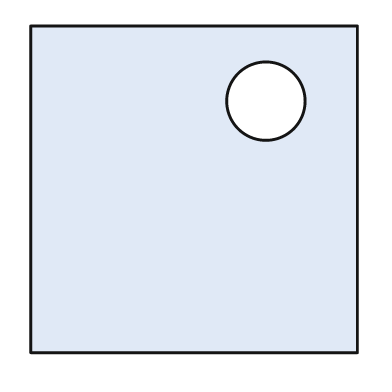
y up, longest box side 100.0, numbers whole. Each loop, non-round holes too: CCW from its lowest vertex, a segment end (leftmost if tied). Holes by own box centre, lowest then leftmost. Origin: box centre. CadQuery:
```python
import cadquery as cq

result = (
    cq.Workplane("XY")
    .moveTo(-50.0, -50.0)
    .lineTo(50.0, -50.0)
    .lineTo(50.0, 50.0)
    .lineTo(-50.0, 50.0)
    .close()
    .moveTo(22.0, 27.0)
    .circle(12.0)
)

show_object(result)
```